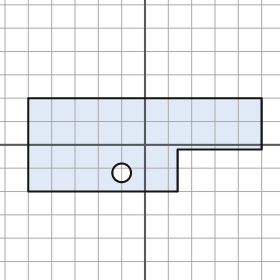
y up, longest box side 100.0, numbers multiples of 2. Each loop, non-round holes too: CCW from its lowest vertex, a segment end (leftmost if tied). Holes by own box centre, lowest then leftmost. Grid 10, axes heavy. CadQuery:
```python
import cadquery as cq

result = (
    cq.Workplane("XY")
    .moveTo(-50.0, -20.0)
    .lineTo(14.0, -20.0)
    .lineTo(14.0, -2.0)
    .lineTo(50.0, -2.0)
    .lineTo(50.0, 20.0)
    .lineTo(-50.0, 20.0)
    .close()
    .moveTo(-10.0, -12.0)
    .circle(4.0)
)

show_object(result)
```